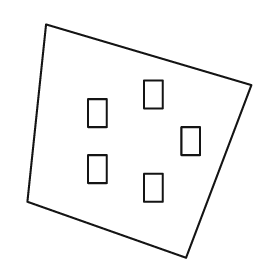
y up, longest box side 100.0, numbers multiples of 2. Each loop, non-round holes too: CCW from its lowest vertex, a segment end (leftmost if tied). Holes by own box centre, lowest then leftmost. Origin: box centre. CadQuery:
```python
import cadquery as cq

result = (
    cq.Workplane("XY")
    .moveTo(20.0, -50.0)
    .lineTo(48.0, 24.0)
    .lineTo(-40.0, 50.0)
    .lineTo(-48.0, -26.0)
    .close()
    .moveTo(2.0, -26.0)
    .lineTo(10.0, -26.0)
    .lineTo(10.0, -14.0)
    .lineTo(2.0, -14.0)
    .close()
    .moveTo(-22.0, -18.0)
    .lineTo(-14.0, -18.0)
    .lineTo(-14.0, -6.0)
    .lineTo(-22.0, -6.0)
    .close()
    .moveTo(18.0, -6.0)
    .lineTo(26.0, -6.0)
    .lineTo(26.0, 6.0)
    .lineTo(18.0, 6.0)
    .close()
    .moveTo(-22.0, 6.0)
    .lineTo(-14.0, 6.0)
    .lineTo(-14.0, 18.0)
    .lineTo(-22.0, 18.0)
    .close()
    .moveTo(2.0, 14.0)
    .lineTo(10.0, 14.0)
    .lineTo(10.0, 26.0)
    .lineTo(2.0, 26.0)
    .close()
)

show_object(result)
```